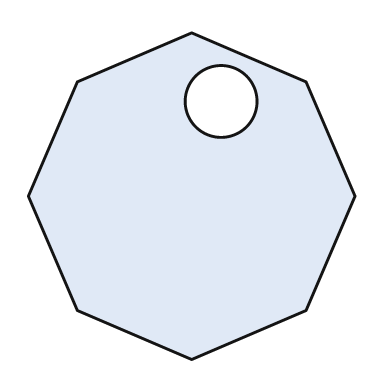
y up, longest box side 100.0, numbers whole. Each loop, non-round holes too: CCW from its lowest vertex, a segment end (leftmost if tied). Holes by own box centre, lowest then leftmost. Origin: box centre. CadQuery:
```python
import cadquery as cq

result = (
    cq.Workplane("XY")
    .moveTo(0.0, -50.0)
    .lineTo(35.0, -35.0)
    .lineTo(50.0, 0.0)
    .lineTo(35.0, 35.0)
    .lineTo(0.0, 50.0)
    .lineTo(-35.0, 35.0)
    .lineTo(-50.0, 0.0)
    .lineTo(-35.0, -35.0)
    .close()
    .moveTo(9.0, 29.0)
    .circle(11.0)
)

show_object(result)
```